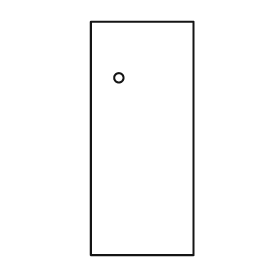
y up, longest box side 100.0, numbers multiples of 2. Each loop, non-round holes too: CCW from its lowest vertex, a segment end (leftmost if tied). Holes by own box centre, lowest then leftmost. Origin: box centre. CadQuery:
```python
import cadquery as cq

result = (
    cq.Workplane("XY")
    .moveTo(-22.0, -50.0)
    .lineTo(22.0, -50.0)
    .lineTo(22.0, 50.0)
    .lineTo(-22.0, 50.0)
    .close()
    .moveTo(-10.0, 26.0)
    .circle(2.0)
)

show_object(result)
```